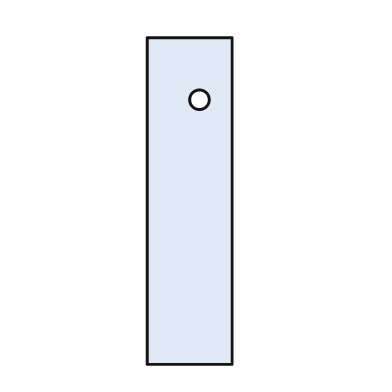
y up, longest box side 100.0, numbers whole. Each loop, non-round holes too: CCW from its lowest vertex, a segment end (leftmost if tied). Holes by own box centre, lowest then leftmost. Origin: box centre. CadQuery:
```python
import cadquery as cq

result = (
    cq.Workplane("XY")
    .moveTo(-13.0, -50.0)
    .lineTo(13.0, -50.0)
    .lineTo(13.0, 50.0)
    .lineTo(-13.0, 50.0)
    .close()
    .moveTo(3.0, 31.0)
    .circle(3.0)
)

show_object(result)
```